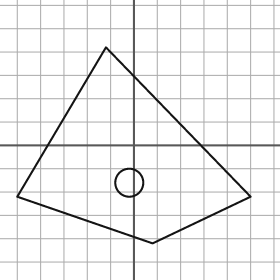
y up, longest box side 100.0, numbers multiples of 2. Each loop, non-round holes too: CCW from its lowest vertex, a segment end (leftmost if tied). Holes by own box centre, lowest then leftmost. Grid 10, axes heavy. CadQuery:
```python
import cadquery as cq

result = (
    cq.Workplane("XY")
    .moveTo(8.0, -42.0)
    .lineTo(50.0, -22.0)
    .lineTo(-12.0, 42.0)
    .lineTo(-50.0, -22.0)
    .close()
    .moveTo(-2.0, -16.0)
    .circle(6.0)
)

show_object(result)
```